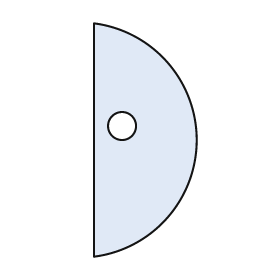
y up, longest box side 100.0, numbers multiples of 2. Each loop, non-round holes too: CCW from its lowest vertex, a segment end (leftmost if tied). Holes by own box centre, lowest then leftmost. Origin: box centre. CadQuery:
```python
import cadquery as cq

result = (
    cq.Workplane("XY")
    .moveTo(-22.0, -50.0)
    .threePointArc((22.0, 0.0), (-22.0, 50.0))
    .close()
    .moveTo(-10.0, 6.0)
    .circle(6.0)
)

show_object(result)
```